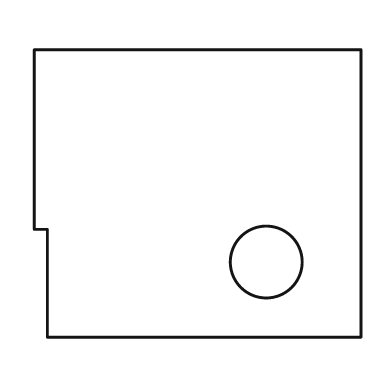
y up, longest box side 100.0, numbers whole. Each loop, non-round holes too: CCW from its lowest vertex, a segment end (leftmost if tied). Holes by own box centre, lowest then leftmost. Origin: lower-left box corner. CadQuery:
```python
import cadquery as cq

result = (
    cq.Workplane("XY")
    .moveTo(4.0, 0.0)
    .lineTo(100.0, 0.0)
    .lineTo(100.0, 88.0)
    .lineTo(0.0, 88.0)
    .lineTo(0.0, 33.0)
    .lineTo(4.0, 33.0)
    .close()
    .moveTo(71.0, 23.0)
    .circle(11.0)
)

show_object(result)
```